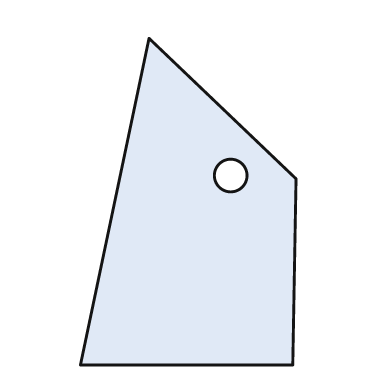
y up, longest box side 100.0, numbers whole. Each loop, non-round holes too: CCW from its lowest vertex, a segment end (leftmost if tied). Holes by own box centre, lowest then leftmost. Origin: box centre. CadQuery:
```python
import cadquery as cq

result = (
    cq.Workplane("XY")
    .moveTo(-33.0, -50.0)
    .lineTo(32.0, -50.0)
    .lineTo(33.0, 7.0)
    .lineTo(-12.0, 50.0)
    .close()
    .moveTo(13.0, 8.0)
    .circle(5.0)
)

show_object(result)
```